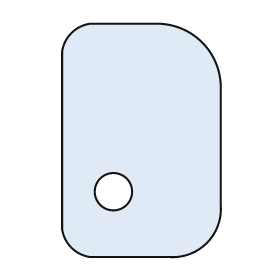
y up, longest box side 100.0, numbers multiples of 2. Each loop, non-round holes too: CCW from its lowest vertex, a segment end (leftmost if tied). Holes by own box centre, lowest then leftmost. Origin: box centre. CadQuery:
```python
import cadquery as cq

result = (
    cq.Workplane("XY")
    .moveTo(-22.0, -50.0)
    .lineTo(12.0, -50.0)
    .threePointArc((28.0, -44.0), (34.0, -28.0))
    .lineTo(34.0, 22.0)
    .threePointArc((26.0, 42.0), (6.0, 50.0))
    .lineTo(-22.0, 50.0)
    .threePointArc((-30.0, 46.0), (-34.0, 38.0))
    .lineTo(-34.0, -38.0)
    .threePointArc((-30.0, -46.0), (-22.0, -50.0))
    .close()
    .moveTo(-12.0, -22.0)
    .circle(8.0)
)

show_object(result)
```